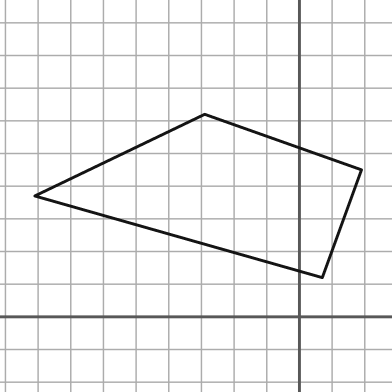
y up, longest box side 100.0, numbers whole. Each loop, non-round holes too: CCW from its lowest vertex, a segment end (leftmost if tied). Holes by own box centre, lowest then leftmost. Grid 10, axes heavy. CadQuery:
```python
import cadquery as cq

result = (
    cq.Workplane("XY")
    .moveTo(7.0, 12.0)
    .lineTo(19.0, 45.0)
    .lineTo(-29.0, 62.0)
    .lineTo(-81.0, 37.0)
    .close()
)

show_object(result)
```